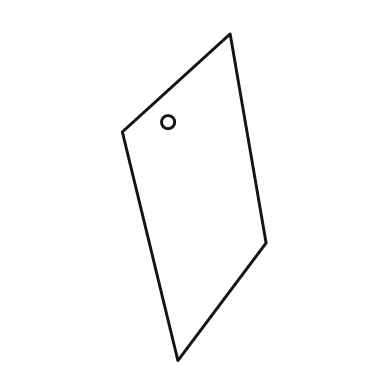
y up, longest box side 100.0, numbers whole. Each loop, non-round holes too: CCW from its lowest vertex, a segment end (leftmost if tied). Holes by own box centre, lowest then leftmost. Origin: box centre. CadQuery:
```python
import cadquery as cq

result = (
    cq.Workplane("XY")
    .moveTo(-5.0, -50.0)
    .lineTo(22.0, -14.0)
    .lineTo(11.0, 50.0)
    .lineTo(-22.0, 20.0)
    .close()
    .moveTo(-8.0, 23.0)
    .circle(2.0)
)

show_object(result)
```